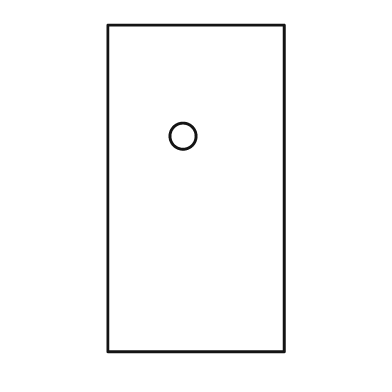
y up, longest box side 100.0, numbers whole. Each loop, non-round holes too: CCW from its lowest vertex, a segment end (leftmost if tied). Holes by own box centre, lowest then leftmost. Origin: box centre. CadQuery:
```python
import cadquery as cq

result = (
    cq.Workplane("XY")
    .moveTo(-27.0, -50.0)
    .lineTo(27.0, -50.0)
    .lineTo(27.0, 50.0)
    .lineTo(-27.0, 50.0)
    .close()
    .moveTo(-4.0, 16.0)
    .circle(4.0)
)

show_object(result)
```